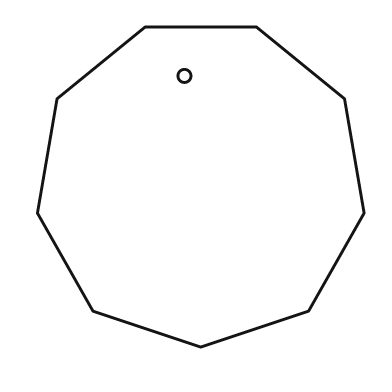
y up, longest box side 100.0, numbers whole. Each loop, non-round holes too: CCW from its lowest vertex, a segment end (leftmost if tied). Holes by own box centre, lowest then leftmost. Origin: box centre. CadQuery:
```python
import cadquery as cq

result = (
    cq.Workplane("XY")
    .moveTo(0.0, -49.0)
    .lineTo(33.0, -38.0)
    .lineTo(50.0, -8.0)
    .lineTo(44.0, 27.0)
    .lineTo(17.0, 49.0)
    .lineTo(-17.0, 49.0)
    .lineTo(-44.0, 27.0)
    .lineTo(-50.0, -8.0)
    .lineTo(-33.0, -38.0)
    .close()
    .moveTo(-5.0, 34.0)
    .circle(2.0)
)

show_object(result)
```